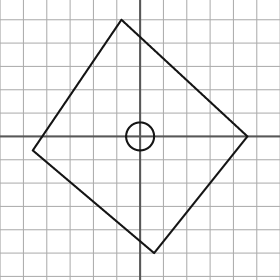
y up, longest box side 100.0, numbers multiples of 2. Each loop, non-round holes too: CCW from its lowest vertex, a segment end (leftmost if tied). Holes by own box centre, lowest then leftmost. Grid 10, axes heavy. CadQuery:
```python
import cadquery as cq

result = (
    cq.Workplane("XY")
    .moveTo(6.0, -50.0)
    .lineTo(46.0, 0.0)
    .lineTo(-8.0, 50.0)
    .lineTo(-46.0, -6.0)
    .close()
    .moveTo(0.0, 0.0)
    .circle(6.0)
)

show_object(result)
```